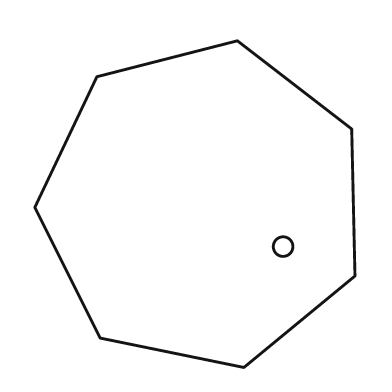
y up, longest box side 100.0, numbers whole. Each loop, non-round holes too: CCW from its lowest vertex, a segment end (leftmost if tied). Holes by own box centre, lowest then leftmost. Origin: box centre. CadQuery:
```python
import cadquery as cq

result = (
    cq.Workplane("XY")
    .moveTo(15.0, -50.0)
    .lineTo(49.0, -22.0)
    .lineTo(48.0, 23.0)
    .lineTo(13.0, 50.0)
    .lineTo(-30.0, 39.0)
    .lineTo(-49.0, -1.0)
    .lineTo(-29.0, -41.0)
    .close()
    .moveTo(27.0, -13.0)
    .circle(3.0)
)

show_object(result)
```